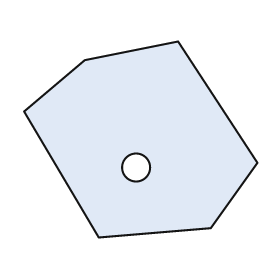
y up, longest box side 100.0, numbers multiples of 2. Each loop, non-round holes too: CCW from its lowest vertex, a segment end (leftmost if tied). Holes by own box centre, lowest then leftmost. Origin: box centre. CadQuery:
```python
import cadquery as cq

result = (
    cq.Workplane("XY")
    .moveTo(-18.0, -42.0)
    .lineTo(30.0, -38.0)
    .lineTo(50.0, -10.0)
    .lineTo(16.0, 42.0)
    .lineTo(-24.0, 34.0)
    .lineTo(-50.0, 12.0)
    .close()
    .moveTo(-2.0, -12.0)
    .circle(6.0)
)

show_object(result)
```